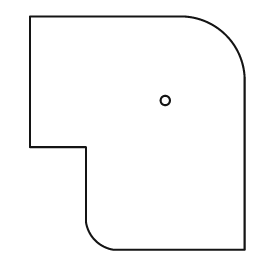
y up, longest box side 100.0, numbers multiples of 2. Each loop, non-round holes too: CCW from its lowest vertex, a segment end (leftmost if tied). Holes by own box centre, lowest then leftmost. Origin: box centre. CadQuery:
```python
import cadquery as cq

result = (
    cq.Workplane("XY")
    .moveTo(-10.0, -50.0)
    .lineTo(46.0, -50.0)
    .lineTo(46.0, 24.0)
    .threePointArc((38.0, 42.0), (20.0, 50.0))
    .lineTo(-46.0, 50.0)
    .lineTo(-46.0, -6.0)
    .lineTo(-22.0, -6.0)
    .lineTo(-22.0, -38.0)
    .threePointArc((-18.0, -46.0), (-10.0, -50.0))
    .close()
    .moveTo(12.0, 14.0)
    .circle(2.0)
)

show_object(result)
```